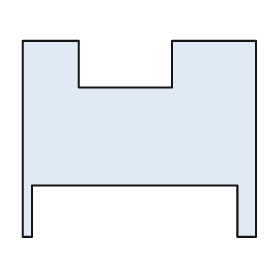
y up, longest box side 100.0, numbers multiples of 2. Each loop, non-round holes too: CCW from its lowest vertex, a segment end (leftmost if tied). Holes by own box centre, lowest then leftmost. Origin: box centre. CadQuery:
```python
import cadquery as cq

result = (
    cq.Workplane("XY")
    .moveTo(-50.0, -42.0)
    .lineTo(-46.0, -42.0)
    .lineTo(-46.0, -20.0)
    .lineTo(42.0, -20.0)
    .lineTo(42.0, -42.0)
    .lineTo(50.0, -42.0)
    .lineTo(50.0, 42.0)
    .lineTo(14.0, 42.0)
    .lineTo(14.0, 22.0)
    .lineTo(-26.0, 22.0)
    .lineTo(-26.0, 42.0)
    .lineTo(-50.0, 42.0)
    .close()
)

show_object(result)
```